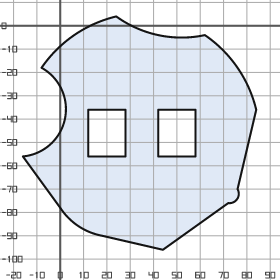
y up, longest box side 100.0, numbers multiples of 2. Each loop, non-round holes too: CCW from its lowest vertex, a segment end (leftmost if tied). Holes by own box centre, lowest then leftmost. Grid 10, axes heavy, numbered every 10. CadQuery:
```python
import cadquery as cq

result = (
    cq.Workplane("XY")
    .moveTo(44.0, -96.0)
    .lineTo(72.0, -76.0)
    .threePointArc((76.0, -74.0), (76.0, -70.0))
    .lineTo(84.0, -36.0)
    .threePointArc((76.0, -18.0), (62.0, -4.0))
    .threePointArc((42.0, -4.0), (24.0, 4.0))
    .threePointArc((6.0, -4.0), (-8.0, -18.0))
    .threePointArc((2.0, -40.0), (-16.0, -56.0))
    .lineTo(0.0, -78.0)
    .threePointArc((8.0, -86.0), (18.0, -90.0))
    .close()
    .moveTo(12.0, -56.0)
    .lineTo(28.0, -56.0)
    .lineTo(28.0, -36.0)
    .lineTo(12.0, -36.0)
    .close()
    .moveTo(42.0, -56.0)
    .lineTo(58.0, -56.0)
    .lineTo(58.0, -36.0)
    .lineTo(42.0, -36.0)
    .close()
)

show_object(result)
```